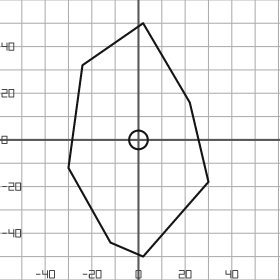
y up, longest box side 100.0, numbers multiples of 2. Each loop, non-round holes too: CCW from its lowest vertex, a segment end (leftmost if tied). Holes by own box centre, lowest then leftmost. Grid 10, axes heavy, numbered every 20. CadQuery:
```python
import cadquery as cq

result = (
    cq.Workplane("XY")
    .moveTo(2.0, -50.0)
    .lineTo(30.0, -18.0)
    .lineTo(22.0, 16.0)
    .lineTo(2.0, 50.0)
    .lineTo(-24.0, 32.0)
    .lineTo(-30.0, -12.0)
    .lineTo(-12.0, -44.0)
    .close()
    .moveTo(0.0, 0.0)
    .circle(4.0)
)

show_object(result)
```